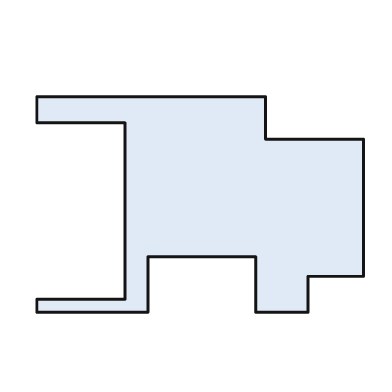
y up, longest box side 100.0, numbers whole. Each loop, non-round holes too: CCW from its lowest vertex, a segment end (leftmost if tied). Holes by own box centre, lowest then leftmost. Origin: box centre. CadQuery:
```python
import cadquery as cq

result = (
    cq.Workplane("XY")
    .moveTo(-50.0, -33.0)
    .lineTo(-16.0, -33.0)
    .lineTo(-16.0, -16.0)
    .lineTo(17.0, -16.0)
    .lineTo(17.0, -33.0)
    .lineTo(33.0, -33.0)
    .lineTo(33.0, -22.0)
    .lineTo(50.0, -22.0)
    .lineTo(50.0, 20.0)
    .lineTo(20.0, 20.0)
    .lineTo(20.0, 33.0)
    .lineTo(-50.0, 33.0)
    .lineTo(-50.0, 25.0)
    .lineTo(-23.0, 25.0)
    .lineTo(-23.0, -29.0)
    .lineTo(-50.0, -29.0)
    .close()
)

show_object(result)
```